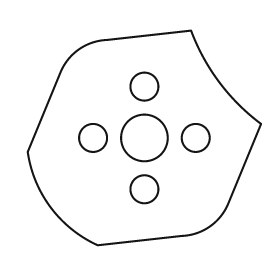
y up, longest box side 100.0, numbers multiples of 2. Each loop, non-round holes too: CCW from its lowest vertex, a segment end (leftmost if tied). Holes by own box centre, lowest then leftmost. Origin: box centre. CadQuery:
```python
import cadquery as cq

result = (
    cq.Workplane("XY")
    .moveTo(-20.0, -46.0)
    .lineTo(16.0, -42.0)
    .threePointArc((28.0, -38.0), (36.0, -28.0))
    .lineTo(50.0, 6.0)
    .threePointArc((32.0, 24.0), (20.0, 46.0))
    .lineTo(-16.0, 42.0)
    .threePointArc((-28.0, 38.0), (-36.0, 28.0))
    .lineTo(-50.0, -6.0)
    .threePointArc((-40.0, -30.0), (-20.0, -46.0))
    .close()
    .moveTo(0.0, -22.0)
    .circle(6.0)
    .moveTo(-22.0, 0.0)
    .circle(6.0)
    .moveTo(0.0, 0.0)
    .circle(10.0)
    .moveTo(22.0, 0.0)
    .circle(6.0)
    .moveTo(0.0, 22.0)
    .circle(6.0)
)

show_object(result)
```